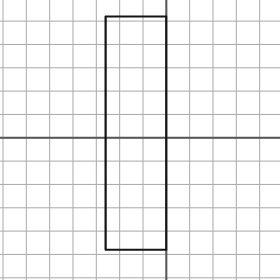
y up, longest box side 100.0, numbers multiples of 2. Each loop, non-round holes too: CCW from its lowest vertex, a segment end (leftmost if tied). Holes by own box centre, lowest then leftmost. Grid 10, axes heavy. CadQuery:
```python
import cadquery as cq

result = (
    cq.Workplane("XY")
    .moveTo(-26.0, -48.0)
    .lineTo(0.0, -48.0)
    .lineTo(0.0, 52.0)
    .lineTo(-26.0, 52.0)
    .close()
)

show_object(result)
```